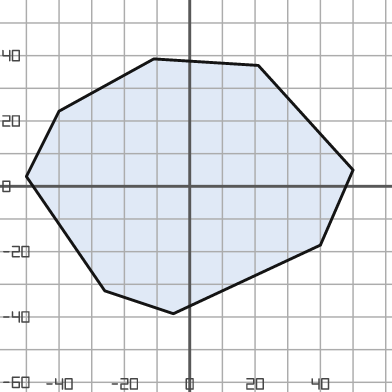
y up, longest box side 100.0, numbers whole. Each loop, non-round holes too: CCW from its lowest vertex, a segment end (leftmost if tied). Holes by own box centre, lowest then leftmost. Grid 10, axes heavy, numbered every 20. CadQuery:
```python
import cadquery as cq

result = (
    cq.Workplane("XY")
    .moveTo(-5.0, -39.0)
    .lineTo(40.0, -18.0)
    .lineTo(50.0, 5.0)
    .lineTo(21.0, 37.0)
    .lineTo(-11.0, 39.0)
    .lineTo(-40.0, 23.0)
    .lineTo(-50.0, 3.0)
    .lineTo(-26.0, -32.0)
    .close()
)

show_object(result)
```